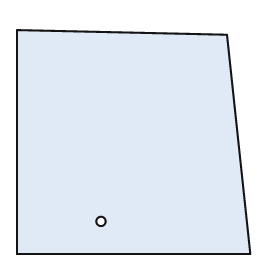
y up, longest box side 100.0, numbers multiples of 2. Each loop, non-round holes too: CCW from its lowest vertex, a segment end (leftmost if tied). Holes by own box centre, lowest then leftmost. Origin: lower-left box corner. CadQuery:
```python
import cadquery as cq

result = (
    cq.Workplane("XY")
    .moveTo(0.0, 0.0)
    .lineTo(100.0, 0.0)
    .lineTo(90.0, 94.0)
    .lineTo(0.0, 96.0)
    .close()
    .moveTo(36.0, 14.0)
    .circle(2.0)
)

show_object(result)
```